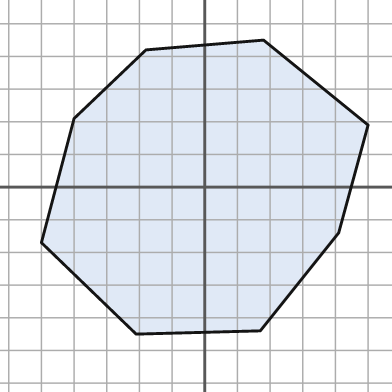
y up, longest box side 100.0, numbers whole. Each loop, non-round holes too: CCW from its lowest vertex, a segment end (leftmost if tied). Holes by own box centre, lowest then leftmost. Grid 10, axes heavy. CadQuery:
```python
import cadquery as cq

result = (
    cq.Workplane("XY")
    .moveTo(-21.0, -45.0)
    .lineTo(17.0, -44.0)
    .lineTo(41.0, -14.0)
    .lineTo(50.0, 19.0)
    .lineTo(18.0, 45.0)
    .lineTo(-18.0, 42.0)
    .lineTo(-40.0, 21.0)
    .lineTo(-50.0, -17.0)
    .close()
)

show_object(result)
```